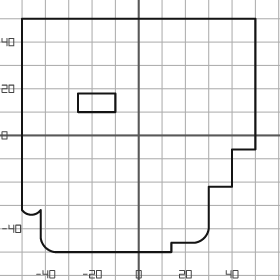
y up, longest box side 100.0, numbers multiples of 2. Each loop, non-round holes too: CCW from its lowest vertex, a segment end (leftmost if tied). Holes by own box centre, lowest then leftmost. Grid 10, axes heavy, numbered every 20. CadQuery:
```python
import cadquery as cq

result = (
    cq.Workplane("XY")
    .moveTo(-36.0, -50.0)
    .lineTo(14.0, -50.0)
    .lineTo(14.0, -46.0)
    .lineTo(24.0, -46.0)
    .threePointArc((28.0, -44.0), (30.0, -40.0))
    .lineTo(30.0, -22.0)
    .lineTo(40.0, -22.0)
    .lineTo(40.0, -6.0)
    .lineTo(50.0, -6.0)
    .lineTo(50.0, 50.0)
    .lineTo(-50.0, 50.0)
    .lineTo(-50.0, -32.0)
    .threePointArc((-46.0, -34.0), (-42.0, -32.0))
    .lineTo(-42.0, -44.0)
    .threePointArc((-40.0, -48.0), (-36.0, -50.0))
    .close()
    .moveTo(-26.0, 10.0)
    .lineTo(-10.0, 10.0)
    .lineTo(-10.0, 18.0)
    .lineTo(-26.0, 18.0)
    .close()
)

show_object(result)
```